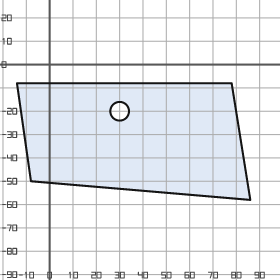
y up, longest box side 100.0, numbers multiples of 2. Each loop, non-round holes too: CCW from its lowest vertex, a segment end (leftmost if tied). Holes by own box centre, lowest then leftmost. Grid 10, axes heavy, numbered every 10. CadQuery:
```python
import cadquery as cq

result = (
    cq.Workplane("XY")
    .moveTo(86.0, -58.0)
    .lineTo(78.0, -8.0)
    .lineTo(-14.0, -8.0)
    .lineTo(-8.0, -50.0)
    .close()
    .moveTo(30.0, -20.0)
    .circle(4.0)
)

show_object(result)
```